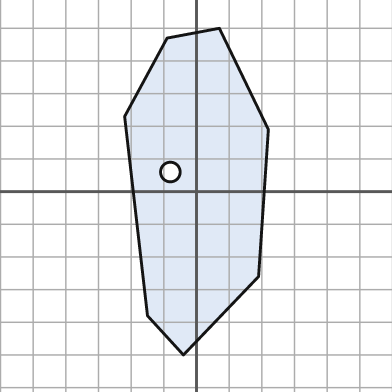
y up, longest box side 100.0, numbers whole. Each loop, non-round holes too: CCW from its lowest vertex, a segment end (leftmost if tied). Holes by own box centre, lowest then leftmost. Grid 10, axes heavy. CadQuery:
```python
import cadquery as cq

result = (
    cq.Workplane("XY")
    .moveTo(-4.0, -50.0)
    .lineTo(19.0, -26.0)
    .lineTo(22.0, 19.0)
    .lineTo(7.0, 50.0)
    .lineTo(-9.0, 47.0)
    .lineTo(-22.0, 23.0)
    .lineTo(-15.0, -38.0)
    .close()
    .moveTo(-8.0, 6.0)
    .circle(3.0)
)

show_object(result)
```